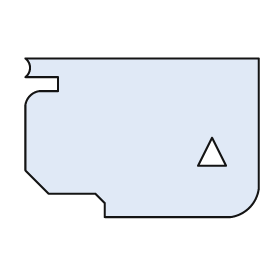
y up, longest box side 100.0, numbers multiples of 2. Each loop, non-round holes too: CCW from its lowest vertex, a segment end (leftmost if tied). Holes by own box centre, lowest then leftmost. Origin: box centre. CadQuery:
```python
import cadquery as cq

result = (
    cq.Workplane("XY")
    .moveTo(-16.0, -34.0)
    .lineTo(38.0, -34.0)
    .threePointArc((46.0, -30.0), (50.0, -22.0))
    .lineTo(50.0, 34.0)
    .lineTo(-50.0, 34.0)
    .threePointArc((-48.0, 30.0), (-50.0, 26.0))
    .lineTo(-36.0, 26.0)
    .lineTo(-36.0, 20.0)
    .lineTo(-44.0, 20.0)
    .threePointArc((-48.0, 18.0), (-50.0, 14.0))
    .lineTo(-50.0, -14.0)
    .lineTo(-40.0, -24.0)
    .lineTo(-20.0, -24.0)
    .lineTo(-16.0, -28.0)
    .close()
    .moveTo(24.0, -12.0)
    .lineTo(36.0, -12.0)
    .lineTo(30.0, 0.0)
    .close()
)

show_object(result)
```